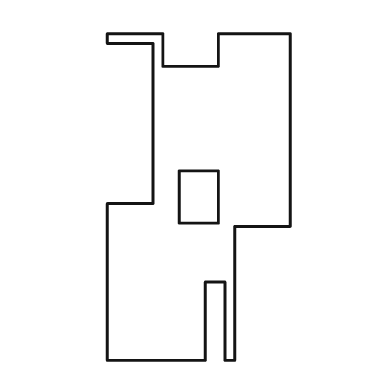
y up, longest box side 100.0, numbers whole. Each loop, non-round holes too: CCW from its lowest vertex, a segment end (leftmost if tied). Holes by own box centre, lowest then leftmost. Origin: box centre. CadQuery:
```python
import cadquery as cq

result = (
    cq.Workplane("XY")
    .moveTo(-28.0, -50.0)
    .lineTo(2.0, -50.0)
    .lineTo(2.0, -26.0)
    .lineTo(8.0, -26.0)
    .lineTo(8.0, -50.0)
    .lineTo(11.0, -50.0)
    .lineTo(11.0, -9.0)
    .lineTo(28.0, -9.0)
    .lineTo(28.0, 50.0)
    .lineTo(6.0, 50.0)
    .lineTo(6.0, 40.0)
    .lineTo(-11.0, 40.0)
    .lineTo(-11.0, 50.0)
    .lineTo(-28.0, 50.0)
    .lineTo(-28.0, 47.0)
    .lineTo(-14.0, 47.0)
    .lineTo(-14.0, -2.0)
    .lineTo(-28.0, -2.0)
    .close()
    .moveTo(-6.0, -8.0)
    .lineTo(6.0, -8.0)
    .lineTo(6.0, 8.0)
    .lineTo(-6.0, 8.0)
    .close()
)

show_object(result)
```